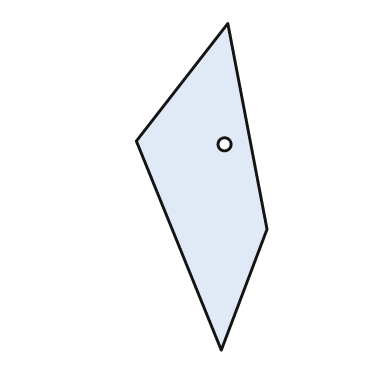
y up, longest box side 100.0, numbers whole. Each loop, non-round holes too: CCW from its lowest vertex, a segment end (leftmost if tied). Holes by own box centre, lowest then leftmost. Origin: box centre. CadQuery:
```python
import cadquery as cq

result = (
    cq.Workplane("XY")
    .moveTo(6.0, -50.0)
    .lineTo(20.0, -13.0)
    .lineTo(8.0, 50.0)
    .lineTo(-20.0, 14.0)
    .close()
    .moveTo(7.0, 13.0)
    .circle(2.0)
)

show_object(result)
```